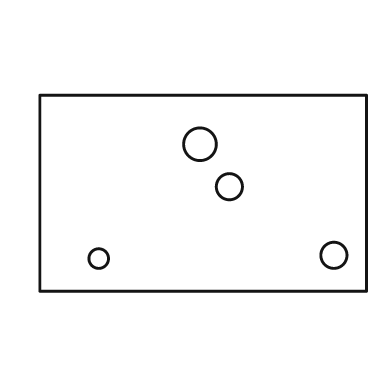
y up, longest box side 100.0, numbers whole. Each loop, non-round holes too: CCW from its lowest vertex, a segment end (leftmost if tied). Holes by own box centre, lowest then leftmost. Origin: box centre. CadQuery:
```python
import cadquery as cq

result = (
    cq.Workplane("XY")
    .moveTo(-50.0, -30.0)
    .lineTo(50.0, -30.0)
    .lineTo(50.0, 30.0)
    .lineTo(-50.0, 30.0)
    .close()
    .moveTo(-32.0, -20.0)
    .circle(3.0)
    .moveTo(40.0, -19.0)
    .circle(4.0)
    .moveTo(8.0, 2.0)
    .circle(4.0)
    .moveTo(-1.0, 15.0)
    .circle(5.0)
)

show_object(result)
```